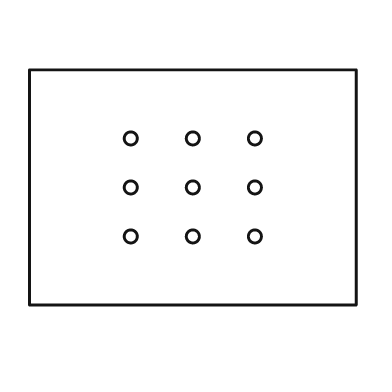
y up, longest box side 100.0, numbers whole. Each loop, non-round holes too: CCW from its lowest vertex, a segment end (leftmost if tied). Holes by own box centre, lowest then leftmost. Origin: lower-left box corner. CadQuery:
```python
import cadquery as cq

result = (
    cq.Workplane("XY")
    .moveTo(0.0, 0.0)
    .lineTo(100.0, 0.0)
    .lineTo(100.0, 72.0)
    .lineTo(0.0, 72.0)
    .close()
    .moveTo(31.0, 21.0)
    .circle(2.0)
    .moveTo(50.0, 21.0)
    .circle(2.0)
    .moveTo(69.0, 21.0)
    .circle(2.0)
    .moveTo(31.0, 36.0)
    .circle(2.0)
    .moveTo(50.0, 36.0)
    .circle(2.0)
    .moveTo(69.0, 36.0)
    .circle(2.0)
    .moveTo(31.0, 51.0)
    .circle(2.0)
    .moveTo(50.0, 51.0)
    .circle(2.0)
    .moveTo(69.0, 51.0)
    .circle(2.0)
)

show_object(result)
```